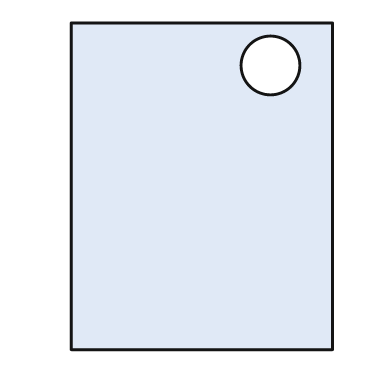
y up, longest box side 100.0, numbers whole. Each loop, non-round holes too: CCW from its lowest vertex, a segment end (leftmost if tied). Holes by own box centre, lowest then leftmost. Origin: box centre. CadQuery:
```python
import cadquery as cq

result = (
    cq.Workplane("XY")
    .moveTo(-40.0, -50.0)
    .lineTo(40.0, -50.0)
    .lineTo(40.0, 50.0)
    .lineTo(-40.0, 50.0)
    .close()
    .moveTo(21.0, 37.0)
    .circle(9.0)
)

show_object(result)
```